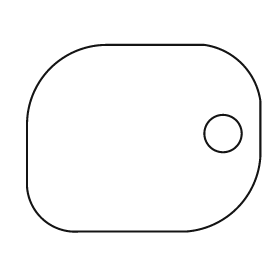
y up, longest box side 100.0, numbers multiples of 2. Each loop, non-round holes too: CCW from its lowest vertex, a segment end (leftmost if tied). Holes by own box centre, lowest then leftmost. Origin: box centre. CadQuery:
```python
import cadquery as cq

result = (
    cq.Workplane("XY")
    .moveTo(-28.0, -40.0)
    .lineTo(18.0, -40.0)
    .threePointArc((40.0, -30.0), (50.0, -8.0))
    .lineTo(50.0, 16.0)
    .threePointArc((42.0, 32.0), (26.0, 40.0))
    .lineTo(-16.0, 40.0)
    .threePointArc((-40.0, 30.0), (-50.0, 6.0))
    .lineTo(-50.0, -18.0)
    .threePointArc((-44.0, -34.0), (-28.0, -40.0))
    .close()
    .moveTo(34.0, 2.0)
    .circle(8.0)
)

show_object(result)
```